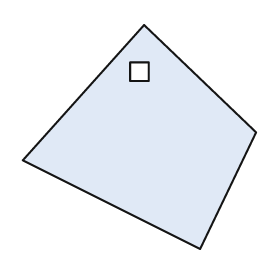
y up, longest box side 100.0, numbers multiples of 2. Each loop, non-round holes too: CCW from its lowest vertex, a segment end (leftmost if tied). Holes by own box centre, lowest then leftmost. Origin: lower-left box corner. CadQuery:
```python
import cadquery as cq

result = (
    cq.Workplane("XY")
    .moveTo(76.0, 0.0)
    .lineTo(100.0, 50.0)
    .lineTo(52.0, 96.0)
    .lineTo(0.0, 38.0)
    .close()
    .moveTo(46.0, 72.0)
    .lineTo(54.0, 72.0)
    .lineTo(54.0, 80.0)
    .lineTo(46.0, 80.0)
    .close()
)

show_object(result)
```